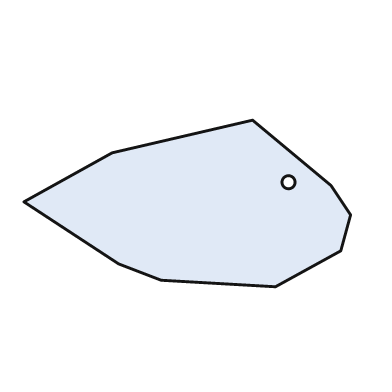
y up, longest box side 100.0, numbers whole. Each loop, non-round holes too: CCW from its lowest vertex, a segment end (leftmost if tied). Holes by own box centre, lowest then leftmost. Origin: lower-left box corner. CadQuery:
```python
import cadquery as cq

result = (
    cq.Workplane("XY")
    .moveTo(77.0, 0.0)
    .lineTo(97.0, 11.0)
    .lineTo(100.0, 22.0)
    .lineTo(94.0, 31.0)
    .lineTo(70.0, 51.0)
    .lineTo(27.0, 41.0)
    .lineTo(0.0, 26.0)
    .lineTo(29.0, 7.0)
    .lineTo(42.0, 2.0)
    .close()
    .moveTo(81.0, 32.0)
    .circle(2.0)
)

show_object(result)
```